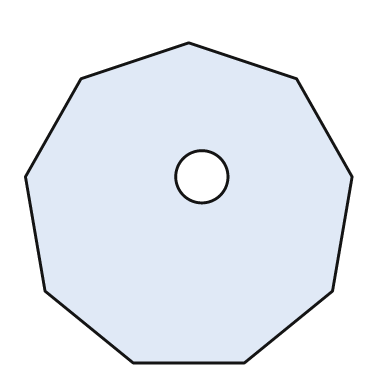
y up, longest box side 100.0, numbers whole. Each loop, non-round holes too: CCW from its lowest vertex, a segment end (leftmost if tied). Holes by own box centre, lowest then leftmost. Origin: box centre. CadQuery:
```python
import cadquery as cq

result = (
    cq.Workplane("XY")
    .moveTo(-17.0, -49.0)
    .lineTo(17.0, -49.0)
    .lineTo(44.0, -27.0)
    .lineTo(50.0, 8.0)
    .lineTo(33.0, 38.0)
    .lineTo(0.0, 49.0)
    .lineTo(-33.0, 38.0)
    .lineTo(-50.0, 8.0)
    .lineTo(-44.0, -27.0)
    .close()
    .moveTo(4.0, 8.0)
    .circle(8.0)
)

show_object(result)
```